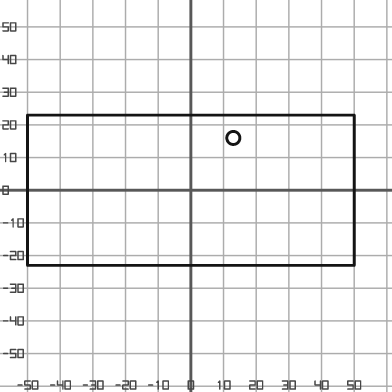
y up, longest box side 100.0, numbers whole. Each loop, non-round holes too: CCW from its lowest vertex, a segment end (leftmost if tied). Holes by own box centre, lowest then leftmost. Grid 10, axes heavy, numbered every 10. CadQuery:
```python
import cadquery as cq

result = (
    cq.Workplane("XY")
    .moveTo(-50.0, -23.0)
    .lineTo(50.0, -23.0)
    .lineTo(50.0, 23.0)
    .lineTo(-50.0, 23.0)
    .close()
    .moveTo(13.0, 16.0)
    .circle(2.0)
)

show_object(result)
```